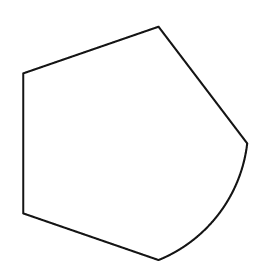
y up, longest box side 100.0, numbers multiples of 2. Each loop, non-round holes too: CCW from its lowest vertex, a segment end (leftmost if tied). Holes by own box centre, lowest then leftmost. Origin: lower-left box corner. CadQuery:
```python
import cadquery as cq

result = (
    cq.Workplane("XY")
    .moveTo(58.0, 0.0)
    .threePointArc((84.0, 20.0), (96.0, 50.0))
    .lineTo(58.0, 100.0)
    .lineTo(0.0, 80.0)
    .lineTo(0.0, 20.0)
    .close()
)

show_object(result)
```